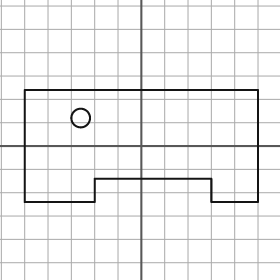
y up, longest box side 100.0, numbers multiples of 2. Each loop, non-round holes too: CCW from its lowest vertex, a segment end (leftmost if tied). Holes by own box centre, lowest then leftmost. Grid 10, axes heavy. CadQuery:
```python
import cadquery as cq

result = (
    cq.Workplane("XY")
    .moveTo(-50.0, -24.0)
    .lineTo(-20.0, -24.0)
    .lineTo(-20.0, -14.0)
    .lineTo(30.0, -14.0)
    .lineTo(30.0, -24.0)
    .lineTo(50.0, -24.0)
    .lineTo(50.0, 24.0)
    .lineTo(-50.0, 24.0)
    .close()
    .moveTo(-26.0, 12.0)
    .circle(4.0)
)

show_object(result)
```